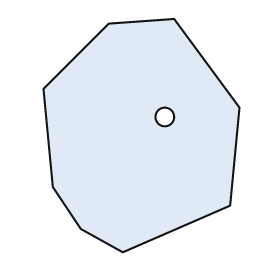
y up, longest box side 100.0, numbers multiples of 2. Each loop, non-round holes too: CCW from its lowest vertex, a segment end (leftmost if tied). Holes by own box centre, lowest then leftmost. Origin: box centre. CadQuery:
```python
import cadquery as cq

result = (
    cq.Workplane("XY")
    .moveTo(-8.0, -50.0)
    .lineTo(38.0, -30.0)
    .lineTo(42.0, 12.0)
    .lineTo(14.0, 50.0)
    .lineTo(-14.0, 48.0)
    .lineTo(-42.0, 20.0)
    .lineTo(-38.0, -22.0)
    .lineTo(-26.0, -40.0)
    .close()
    .moveTo(10.0, 8.0)
    .circle(4.0)
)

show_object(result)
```